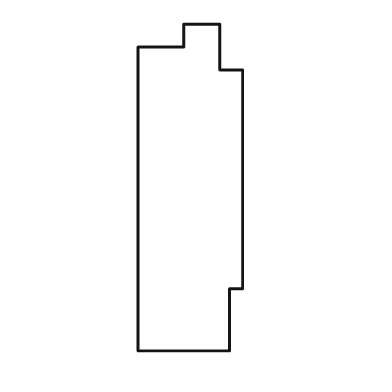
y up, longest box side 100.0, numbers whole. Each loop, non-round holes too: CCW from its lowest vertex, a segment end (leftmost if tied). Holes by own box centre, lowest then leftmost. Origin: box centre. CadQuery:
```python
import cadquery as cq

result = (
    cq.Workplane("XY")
    .moveTo(-16.0, -50.0)
    .lineTo(12.0, -50.0)
    .lineTo(12.0, -31.0)
    .lineTo(16.0, -31.0)
    .lineTo(16.0, 36.0)
    .lineTo(9.0, 36.0)
    .lineTo(9.0, 50.0)
    .lineTo(-2.0, 50.0)
    .lineTo(-2.0, 43.0)
    .lineTo(-16.0, 43.0)
    .close()
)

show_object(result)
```